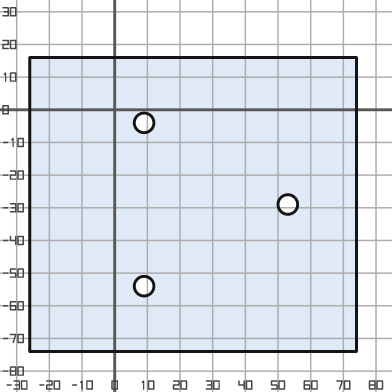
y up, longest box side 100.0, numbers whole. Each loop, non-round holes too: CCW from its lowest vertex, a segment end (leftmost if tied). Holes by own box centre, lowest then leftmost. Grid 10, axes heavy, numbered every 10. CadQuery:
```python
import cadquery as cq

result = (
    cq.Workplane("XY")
    .moveTo(-26.0, -74.0)
    .lineTo(74.0, -74.0)
    .lineTo(74.0, 16.0)
    .lineTo(-26.0, 16.0)
    .close()
    .moveTo(9.0, -54.0)
    .circle(3.0)
    .moveTo(53.0, -29.0)
    .circle(3.0)
    .moveTo(9.0, -4.0)
    .circle(3.0)
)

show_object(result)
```